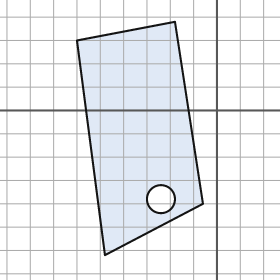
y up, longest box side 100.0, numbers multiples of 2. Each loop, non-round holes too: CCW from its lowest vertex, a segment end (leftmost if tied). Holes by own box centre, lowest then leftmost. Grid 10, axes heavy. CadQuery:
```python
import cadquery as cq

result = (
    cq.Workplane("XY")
    .moveTo(-48.0, -62.0)
    .lineTo(-6.0, -40.0)
    .lineTo(-18.0, 38.0)
    .lineTo(-60.0, 30.0)
    .close()
    .moveTo(-24.0, -38.0)
    .circle(6.0)
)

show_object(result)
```